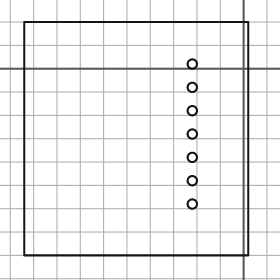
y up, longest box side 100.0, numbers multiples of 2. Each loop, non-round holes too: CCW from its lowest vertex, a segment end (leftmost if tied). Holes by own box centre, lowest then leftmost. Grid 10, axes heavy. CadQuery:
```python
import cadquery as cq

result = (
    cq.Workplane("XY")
    .moveTo(-94.0, -80.0)
    .lineTo(2.0, -80.0)
    .lineTo(2.0, 20.0)
    .lineTo(-94.0, 20.0)
    .close()
    .moveTo(-22.0, -58.0)
    .circle(2.0)
    .moveTo(-22.0, -48.0)
    .circle(2.0)
    .moveTo(-22.0, -38.0)
    .circle(2.0)
    .moveTo(-22.0, -28.0)
    .circle(2.0)
    .moveTo(-22.0, -18.0)
    .circle(2.0)
    .moveTo(-22.0, -8.0)
    .circle(2.0)
    .moveTo(-22.0, 2.0)
    .circle(2.0)
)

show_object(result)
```